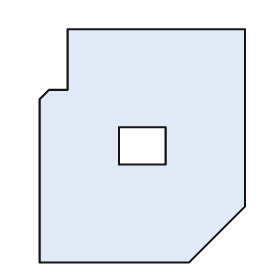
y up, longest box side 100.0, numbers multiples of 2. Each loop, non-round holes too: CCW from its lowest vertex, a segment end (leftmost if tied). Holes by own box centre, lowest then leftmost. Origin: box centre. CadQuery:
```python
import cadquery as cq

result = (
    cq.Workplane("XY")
    .moveTo(-44.0, -50.0)
    .lineTo(20.0, -50.0)
    .lineTo(44.0, -26.0)
    .lineTo(44.0, 50.0)
    .lineTo(-32.0, 50.0)
    .lineTo(-32.0, 24.0)
    .lineTo(-40.0, 24.0)
    .lineTo(-44.0, 20.0)
    .close()
    .moveTo(-10.0, -8.0)
    .lineTo(10.0, -8.0)
    .lineTo(10.0, 8.0)
    .lineTo(-10.0, 8.0)
    .close()
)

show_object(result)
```